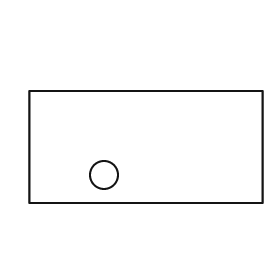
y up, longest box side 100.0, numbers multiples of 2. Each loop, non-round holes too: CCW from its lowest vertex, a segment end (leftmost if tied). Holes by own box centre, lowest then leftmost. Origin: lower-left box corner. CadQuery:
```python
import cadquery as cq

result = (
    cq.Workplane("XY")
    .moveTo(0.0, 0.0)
    .lineTo(100.0, 0.0)
    .lineTo(100.0, 48.0)
    .lineTo(0.0, 48.0)
    .close()
    .moveTo(32.0, 12.0)
    .circle(6.0)
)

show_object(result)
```